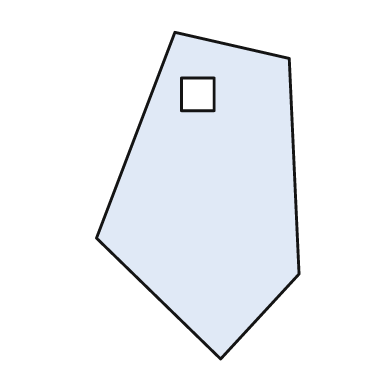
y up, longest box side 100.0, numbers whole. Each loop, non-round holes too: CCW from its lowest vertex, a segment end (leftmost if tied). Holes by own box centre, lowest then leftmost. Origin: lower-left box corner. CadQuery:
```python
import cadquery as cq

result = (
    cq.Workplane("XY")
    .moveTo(38.0, 0.0)
    .lineTo(62.0, 26.0)
    .lineTo(59.0, 92.0)
    .lineTo(24.0, 100.0)
    .lineTo(0.0, 37.0)
    .close()
    .moveTo(26.0, 76.0)
    .lineTo(36.0, 76.0)
    .lineTo(36.0, 86.0)
    .lineTo(26.0, 86.0)
    .close()
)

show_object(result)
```